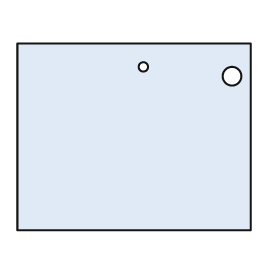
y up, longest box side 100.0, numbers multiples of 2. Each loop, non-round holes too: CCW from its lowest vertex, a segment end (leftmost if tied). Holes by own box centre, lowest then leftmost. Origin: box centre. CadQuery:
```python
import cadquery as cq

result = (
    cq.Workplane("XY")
    .moveTo(-50.0, -40.0)
    .lineTo(50.0, -40.0)
    .lineTo(50.0, 40.0)
    .lineTo(-50.0, 40.0)
    .close()
    .moveTo(42.0, 26.0)
    .circle(4.0)
    .moveTo(4.0, 30.0)
    .circle(2.0)
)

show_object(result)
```